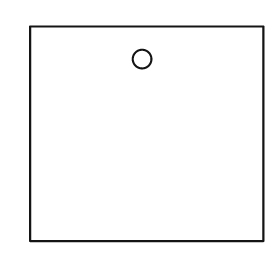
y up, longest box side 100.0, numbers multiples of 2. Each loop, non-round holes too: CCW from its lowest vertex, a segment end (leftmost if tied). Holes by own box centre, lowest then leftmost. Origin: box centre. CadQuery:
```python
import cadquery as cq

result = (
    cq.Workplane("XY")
    .moveTo(-50.0, -46.0)
    .lineTo(50.0, -46.0)
    .lineTo(50.0, 46.0)
    .lineTo(-50.0, 46.0)
    .close()
    .moveTo(-2.0, 32.0)
    .circle(4.0)
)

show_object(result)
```